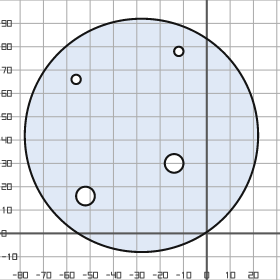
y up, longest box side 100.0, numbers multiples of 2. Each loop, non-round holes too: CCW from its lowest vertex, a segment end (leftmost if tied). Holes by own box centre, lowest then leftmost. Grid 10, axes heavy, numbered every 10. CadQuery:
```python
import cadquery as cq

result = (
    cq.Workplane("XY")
    .moveTo(-28.0, 42.0)
    .circle(50.0)
    .moveTo(-52.0, 16.0)
    .circle(4.0)
    .moveTo(-14.0, 30.0)
    .circle(4.0)
    .moveTo(-56.0, 66.0)
    .circle(2.0)
    .moveTo(-12.0, 78.0)
    .circle(2.0)
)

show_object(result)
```